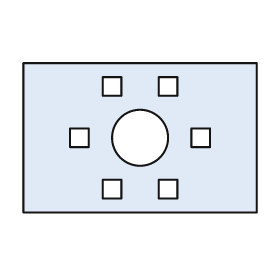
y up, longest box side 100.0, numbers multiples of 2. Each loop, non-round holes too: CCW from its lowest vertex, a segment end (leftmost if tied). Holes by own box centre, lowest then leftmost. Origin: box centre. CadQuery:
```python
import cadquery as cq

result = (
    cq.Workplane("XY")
    .moveTo(-50.0, -32.0)
    .lineTo(50.0, -32.0)
    .lineTo(50.0, 32.0)
    .lineTo(-50.0, 32.0)
    .close()
    .moveTo(-16.0, -26.0)
    .lineTo(-8.0, -26.0)
    .lineTo(-8.0, -18.0)
    .lineTo(-16.0, -18.0)
    .close()
    .moveTo(8.0, -26.0)
    .lineTo(16.0, -26.0)
    .lineTo(16.0, -18.0)
    .lineTo(8.0, -18.0)
    .close()
    .moveTo(-30.0, -4.0)
    .lineTo(-22.0, -4.0)
    .lineTo(-22.0, 4.0)
    .lineTo(-30.0, 4.0)
    .close()
    .moveTo(0.0, 0.0)
    .circle(12.0)
    .moveTo(22.0, -4.0)
    .lineTo(30.0, -4.0)
    .lineTo(30.0, 4.0)
    .lineTo(22.0, 4.0)
    .close()
    .moveTo(-16.0, 18.0)
    .lineTo(-8.0, 18.0)
    .lineTo(-8.0, 26.0)
    .lineTo(-16.0, 26.0)
    .close()
    .moveTo(8.0, 18.0)
    .lineTo(16.0, 18.0)
    .lineTo(16.0, 26.0)
    .lineTo(8.0, 26.0)
    .close()
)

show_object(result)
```